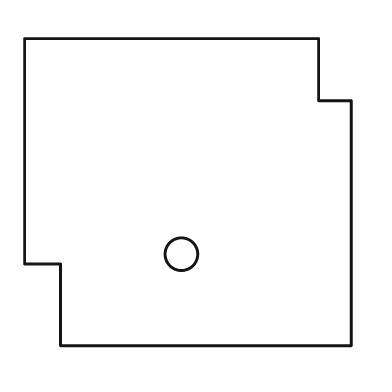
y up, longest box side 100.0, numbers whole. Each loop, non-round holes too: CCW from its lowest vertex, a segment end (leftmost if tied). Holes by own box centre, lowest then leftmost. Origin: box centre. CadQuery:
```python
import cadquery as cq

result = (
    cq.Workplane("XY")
    .moveTo(-39.0, -47.0)
    .lineTo(50.0, -47.0)
    .lineTo(50.0, 28.0)
    .lineTo(40.0, 28.0)
    .lineTo(40.0, 47.0)
    .lineTo(-50.0, 47.0)
    .lineTo(-50.0, -22.0)
    .lineTo(-39.0, -22.0)
    .close()
    .moveTo(-2.0, -19.0)
    .circle(5.0)
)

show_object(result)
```